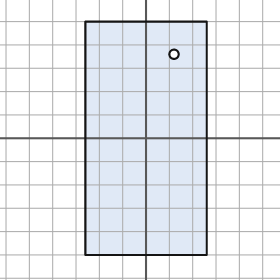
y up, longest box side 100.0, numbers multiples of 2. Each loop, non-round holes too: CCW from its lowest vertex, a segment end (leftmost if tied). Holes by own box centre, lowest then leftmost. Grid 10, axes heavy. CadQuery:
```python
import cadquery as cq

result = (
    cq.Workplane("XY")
    .moveTo(-26.0, -50.0)
    .lineTo(26.0, -50.0)
    .lineTo(26.0, 50.0)
    .lineTo(-26.0, 50.0)
    .close()
    .moveTo(12.0, 36.0)
    .circle(2.0)
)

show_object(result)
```